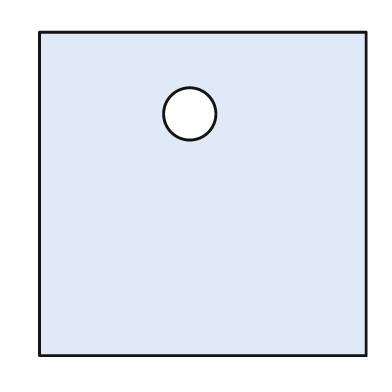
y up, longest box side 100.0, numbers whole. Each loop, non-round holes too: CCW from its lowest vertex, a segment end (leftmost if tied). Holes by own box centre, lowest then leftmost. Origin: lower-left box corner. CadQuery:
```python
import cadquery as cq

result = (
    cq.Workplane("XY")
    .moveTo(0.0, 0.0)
    .lineTo(100.0, 0.0)
    .lineTo(100.0, 99.0)
    .lineTo(0.0, 99.0)
    .close()
    .moveTo(46.0, 74.0)
    .circle(8.0)
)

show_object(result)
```